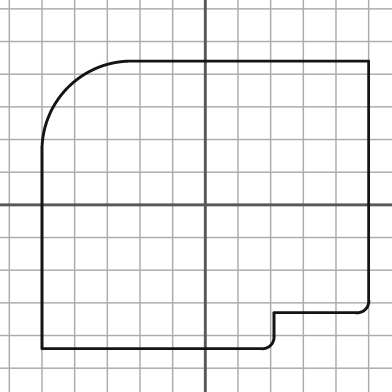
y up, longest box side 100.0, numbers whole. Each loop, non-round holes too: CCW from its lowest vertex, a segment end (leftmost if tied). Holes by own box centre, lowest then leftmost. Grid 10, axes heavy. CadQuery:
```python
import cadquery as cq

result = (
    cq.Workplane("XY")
    .moveTo(-50.0, -44.0)
    .lineTo(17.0, -44.0)
    .threePointArc((20.0, -43.0), (21.0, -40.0))
    .lineTo(21.0, -33.0)
    .lineTo(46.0, -33.0)
    .threePointArc((49.0, -32.0), (50.0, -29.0))
    .lineTo(50.0, 44.0)
    .lineTo(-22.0, 44.0)
    .threePointArc((-42.0, 36.0), (-50.0, 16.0))
    .close()
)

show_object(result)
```